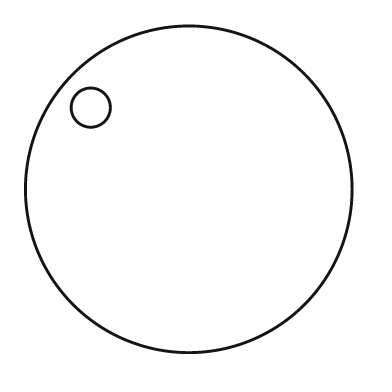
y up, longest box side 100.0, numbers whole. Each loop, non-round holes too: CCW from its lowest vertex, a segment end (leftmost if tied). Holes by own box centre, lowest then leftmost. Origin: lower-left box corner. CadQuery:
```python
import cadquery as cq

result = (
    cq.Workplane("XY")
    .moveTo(50.0, 50.0)
    .circle(50.0)
    .moveTo(20.0, 75.0)
    .circle(6.0)
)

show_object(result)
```